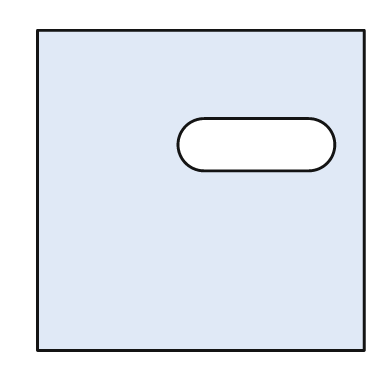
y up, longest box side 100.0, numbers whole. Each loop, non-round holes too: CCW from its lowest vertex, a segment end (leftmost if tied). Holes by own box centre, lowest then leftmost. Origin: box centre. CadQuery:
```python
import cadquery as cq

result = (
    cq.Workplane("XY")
    .moveTo(-50.0, -49.0)
    .lineTo(50.0, -49.0)
    .lineTo(50.0, 49.0)
    .lineTo(-50.0, 49.0)
    .close()
    .moveTo(1.0, 6.0)
    .lineTo(33.0, 6.0)
    .threePointArc((41.0, 14.0), (33.0, 22.0))
    .lineTo(1.0, 22.0)
    .threePointArc((-7.0, 14.0), (1.0, 6.0))
    .close()
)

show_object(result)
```